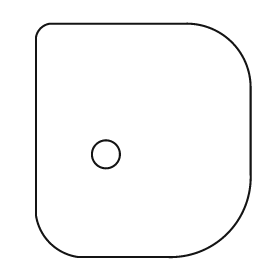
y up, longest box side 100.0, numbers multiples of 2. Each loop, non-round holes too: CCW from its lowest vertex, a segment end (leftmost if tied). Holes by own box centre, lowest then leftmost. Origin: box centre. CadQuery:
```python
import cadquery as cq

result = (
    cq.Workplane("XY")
    .moveTo(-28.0, -50.0)
    .lineTo(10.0, -50.0)
    .threePointArc((36.0, -40.0), (46.0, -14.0))
    .lineTo(46.0, 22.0)
    .threePointArc((38.0, 42.0), (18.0, 50.0))
    .lineTo(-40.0, 50.0)
    .threePointArc((-44.0, 48.0), (-46.0, 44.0))
    .lineTo(-46.0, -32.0)
    .threePointArc((-40.0, -44.0), (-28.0, -50.0))
    .close()
    .moveTo(-16.0, -6.0)
    .circle(6.0)
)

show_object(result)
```